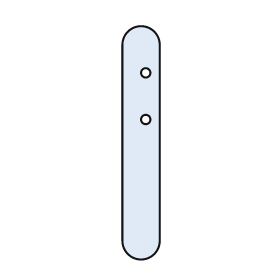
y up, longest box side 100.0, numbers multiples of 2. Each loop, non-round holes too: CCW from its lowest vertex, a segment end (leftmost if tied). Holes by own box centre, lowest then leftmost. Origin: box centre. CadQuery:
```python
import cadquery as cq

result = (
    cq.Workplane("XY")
    .moveTo(-8.0, -42.0)
    .threePointArc((0.0, -50.0), (8.0, -42.0))
    .lineTo(8.0, 42.0)
    .threePointArc((0.0, 50.0), (-8.0, 42.0))
    .close()
    .moveTo(2.0, 10.0)
    .circle(2.0)
    .moveTo(2.0, 30.0)
    .circle(2.0)
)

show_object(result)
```